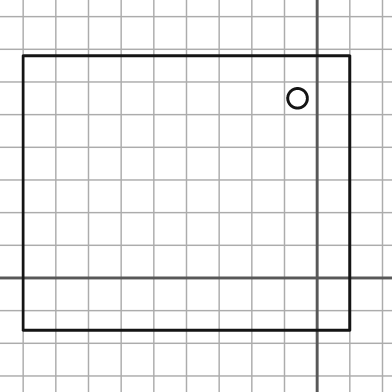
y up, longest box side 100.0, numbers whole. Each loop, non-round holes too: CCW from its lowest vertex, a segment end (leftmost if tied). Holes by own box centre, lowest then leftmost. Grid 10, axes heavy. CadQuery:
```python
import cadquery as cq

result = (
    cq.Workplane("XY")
    .moveTo(-90.0, -16.0)
    .lineTo(10.0, -16.0)
    .lineTo(10.0, 68.0)
    .lineTo(-90.0, 68.0)
    .close()
    .moveTo(-6.0, 55.0)
    .circle(3.0)
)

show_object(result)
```